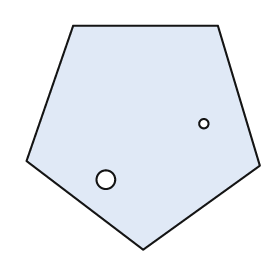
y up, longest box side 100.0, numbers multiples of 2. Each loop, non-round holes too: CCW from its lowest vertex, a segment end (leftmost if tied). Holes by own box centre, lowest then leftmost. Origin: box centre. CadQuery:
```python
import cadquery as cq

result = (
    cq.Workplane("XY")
    .moveTo(0.0, -48.0)
    .lineTo(50.0, -12.0)
    .lineTo(32.0, 48.0)
    .lineTo(-30.0, 48.0)
    .lineTo(-50.0, -10.0)
    .close()
    .moveTo(-16.0, -18.0)
    .circle(4.0)
    .moveTo(26.0, 6.0)
    .circle(2.0)
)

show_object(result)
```